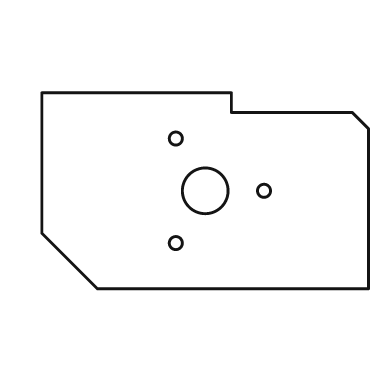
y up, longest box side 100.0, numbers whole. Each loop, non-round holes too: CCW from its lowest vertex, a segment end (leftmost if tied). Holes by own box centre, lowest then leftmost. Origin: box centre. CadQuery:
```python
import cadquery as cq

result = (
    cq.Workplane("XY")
    .moveTo(-33.0, -30.0)
    .lineTo(50.0, -30.0)
    .lineTo(50.0, 19.0)
    .lineTo(45.0, 24.0)
    .lineTo(8.0, 24.0)
    .lineTo(8.0, 30.0)
    .lineTo(-50.0, 30.0)
    .lineTo(-50.0, -13.0)
    .close()
    .moveTo(-9.0, -16.0)
    .circle(2.0)
    .moveTo(0.0, 0.0)
    .circle(7.0)
    .moveTo(18.0, 0.0)
    .circle(2.0)
    .moveTo(-9.0, 16.0)
    .circle(2.0)
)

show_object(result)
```